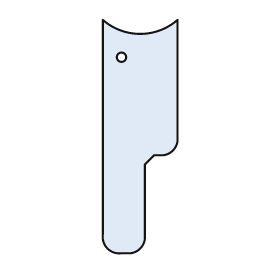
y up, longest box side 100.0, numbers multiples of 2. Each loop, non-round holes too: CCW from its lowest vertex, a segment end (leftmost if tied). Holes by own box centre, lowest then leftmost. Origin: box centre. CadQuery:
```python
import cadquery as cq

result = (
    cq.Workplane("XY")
    .moveTo(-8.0, -50.0)
    .lineTo(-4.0, -50.0)
    .threePointArc((0.0, -48.0), (2.0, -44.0))
    .lineTo(2.0, -12.0)
    .lineTo(6.0, -8.0)
    .lineTo(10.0, -8.0)
    .threePointArc((14.0, -6.0), (16.0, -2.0))
    .lineTo(16.0, 50.0)
    .threePointArc((0.0, 44.0), (-16.0, 50.0))
    .lineTo(-16.0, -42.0)
    .threePointArc((-14.0, -48.0), (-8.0, -50.0))
    .close()
    .moveTo(-8.0, 34.0)
    .circle(2.0)
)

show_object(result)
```